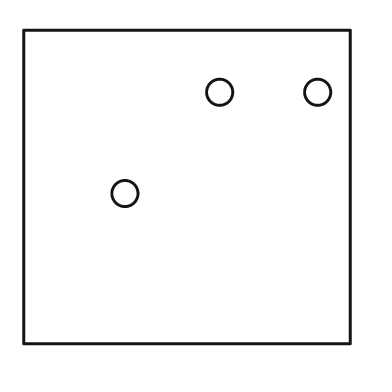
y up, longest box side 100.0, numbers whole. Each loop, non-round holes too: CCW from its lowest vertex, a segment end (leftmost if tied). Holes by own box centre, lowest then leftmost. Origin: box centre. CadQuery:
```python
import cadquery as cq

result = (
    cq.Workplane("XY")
    .moveTo(-50.0, -48.0)
    .lineTo(50.0, -48.0)
    .lineTo(50.0, 48.0)
    .lineTo(-50.0, 48.0)
    .close()
    .moveTo(-19.0, -2.0)
    .circle(4.0)
    .moveTo(10.0, 29.0)
    .circle(4.0)
    .moveTo(40.0, 29.0)
    .circle(4.0)
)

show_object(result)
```